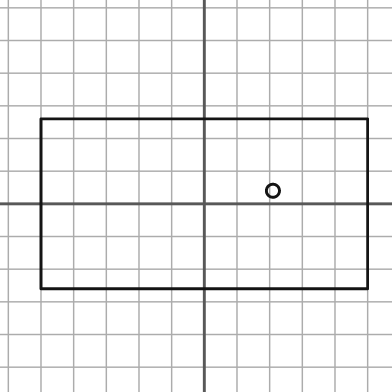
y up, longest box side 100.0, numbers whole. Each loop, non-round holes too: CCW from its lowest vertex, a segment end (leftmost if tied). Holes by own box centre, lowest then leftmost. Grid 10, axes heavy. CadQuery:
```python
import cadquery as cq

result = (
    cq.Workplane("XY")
    .moveTo(-50.0, -26.0)
    .lineTo(50.0, -26.0)
    .lineTo(50.0, 26.0)
    .lineTo(-50.0, 26.0)
    .close()
    .moveTo(21.0, 4.0)
    .circle(2.0)
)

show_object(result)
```